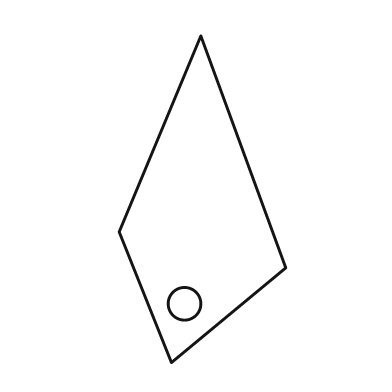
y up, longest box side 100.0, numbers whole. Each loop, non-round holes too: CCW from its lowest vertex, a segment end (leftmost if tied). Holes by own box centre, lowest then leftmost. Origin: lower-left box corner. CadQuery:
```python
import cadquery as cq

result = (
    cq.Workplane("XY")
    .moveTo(16.0, 0.0)
    .lineTo(51.0, 29.0)
    .lineTo(25.0, 100.0)
    .lineTo(0.0, 40.0)
    .close()
    .moveTo(20.0, 18.0)
    .circle(5.0)
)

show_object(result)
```